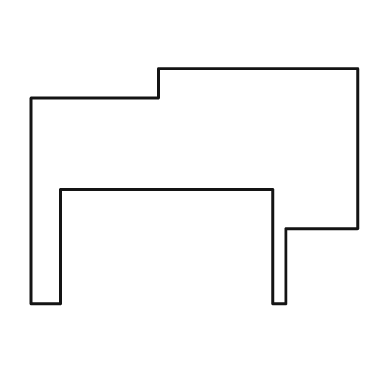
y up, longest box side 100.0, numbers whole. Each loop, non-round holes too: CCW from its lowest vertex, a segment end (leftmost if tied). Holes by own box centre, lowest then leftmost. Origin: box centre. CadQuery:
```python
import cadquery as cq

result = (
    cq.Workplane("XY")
    .moveTo(-50.0, -36.0)
    .lineTo(-41.0, -36.0)
    .lineTo(-41.0, -1.0)
    .lineTo(24.0, -1.0)
    .lineTo(24.0, -36.0)
    .lineTo(28.0, -36.0)
    .lineTo(28.0, -13.0)
    .lineTo(50.0, -13.0)
    .lineTo(50.0, 36.0)
    .lineTo(-11.0, 36.0)
    .lineTo(-11.0, 27.0)
    .lineTo(-50.0, 27.0)
    .close()
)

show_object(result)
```